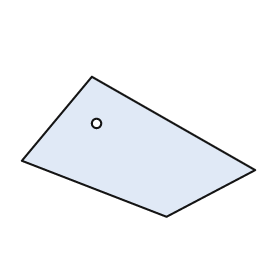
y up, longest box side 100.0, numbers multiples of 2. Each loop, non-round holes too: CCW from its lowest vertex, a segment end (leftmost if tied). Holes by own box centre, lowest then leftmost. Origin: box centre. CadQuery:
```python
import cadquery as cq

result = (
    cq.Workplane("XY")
    .moveTo(12.0, -30.0)
    .lineTo(50.0, -10.0)
    .lineTo(-20.0, 30.0)
    .lineTo(-50.0, -6.0)
    .close()
    .moveTo(-18.0, 10.0)
    .circle(2.0)
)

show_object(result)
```